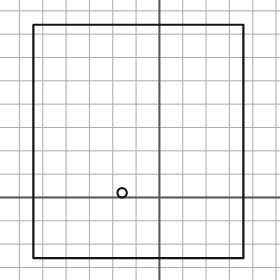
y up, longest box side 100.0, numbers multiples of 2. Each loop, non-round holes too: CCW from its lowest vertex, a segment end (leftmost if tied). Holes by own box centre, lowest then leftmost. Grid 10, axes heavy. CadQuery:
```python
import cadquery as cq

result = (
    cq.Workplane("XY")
    .moveTo(-54.0, -26.0)
    .lineTo(36.0, -26.0)
    .lineTo(36.0, 74.0)
    .lineTo(-54.0, 74.0)
    .close()
    .moveTo(-16.0, 2.0)
    .circle(2.0)
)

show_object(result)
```